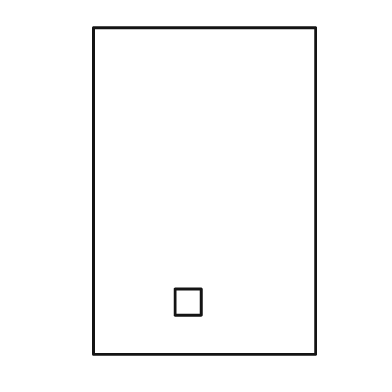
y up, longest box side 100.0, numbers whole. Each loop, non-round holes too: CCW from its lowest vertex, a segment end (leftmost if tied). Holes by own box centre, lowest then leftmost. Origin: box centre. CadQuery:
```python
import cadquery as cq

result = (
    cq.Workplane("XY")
    .moveTo(-34.0, -50.0)
    .lineTo(34.0, -50.0)
    .lineTo(34.0, 50.0)
    .lineTo(-34.0, 50.0)
    .close()
    .moveTo(-9.0, -38.0)
    .lineTo(-1.0, -38.0)
    .lineTo(-1.0, -30.0)
    .lineTo(-9.0, -30.0)
    .close()
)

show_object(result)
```